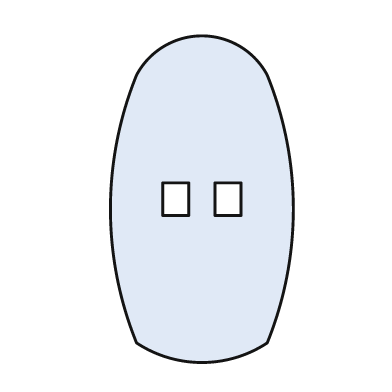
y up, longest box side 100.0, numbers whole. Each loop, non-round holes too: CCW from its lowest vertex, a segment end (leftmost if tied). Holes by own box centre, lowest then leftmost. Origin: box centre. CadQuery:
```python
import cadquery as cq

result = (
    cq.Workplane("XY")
    .moveTo(-20.0, -44.0)
    .threePointArc((0.0, -50.0), (20.0, -44.0))
    .threePointArc((28.0, -3.0), (20.0, 38.0))
    .threePointArc((0.0, 50.0), (-20.0, 38.0))
    .threePointArc((-28.0, -3.0), (-20.0, -44.0))
    .close()
    .moveTo(-12.0, -5.0)
    .lineTo(-4.0, -5.0)
    .lineTo(-4.0, 5.0)
    .lineTo(-12.0, 5.0)
    .close()
    .moveTo(4.0, -5.0)
    .lineTo(12.0, -5.0)
    .lineTo(12.0, 5.0)
    .lineTo(4.0, 5.0)
    .close()
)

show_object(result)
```